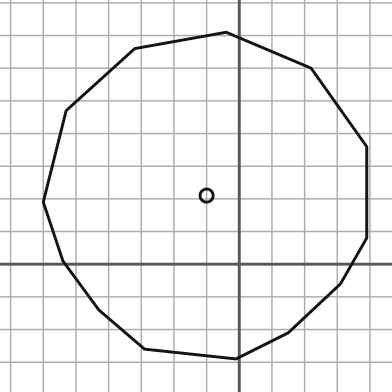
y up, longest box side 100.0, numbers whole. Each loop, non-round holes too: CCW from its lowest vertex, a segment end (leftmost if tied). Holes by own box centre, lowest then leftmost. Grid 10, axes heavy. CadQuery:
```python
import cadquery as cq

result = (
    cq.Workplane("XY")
    .moveTo(-1.0, -29.0)
    .lineTo(15.0, -21.0)
    .lineTo(31.0, -6.0)
    .lineTo(39.0, 8.0)
    .lineTo(39.0, 36.0)
    .lineTo(22.0, 60.0)
    .lineTo(-4.0, 71.0)
    .lineTo(-32.0, 66.0)
    .lineTo(-53.0, 47.0)
    .lineTo(-60.0, 19.0)
    .lineTo(-54.0, 1.0)
    .lineTo(-43.0, -14.0)
    .lineTo(-29.0, -26.0)
    .close()
    .moveTo(-10.0, 21.0)
    .circle(2.0)
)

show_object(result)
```